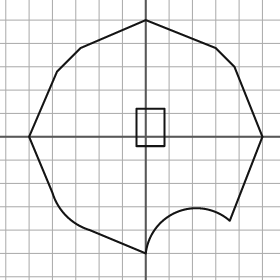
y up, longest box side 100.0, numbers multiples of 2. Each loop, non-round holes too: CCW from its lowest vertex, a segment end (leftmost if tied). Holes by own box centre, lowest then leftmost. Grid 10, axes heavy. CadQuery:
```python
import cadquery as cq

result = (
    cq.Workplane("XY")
    .moveTo(0.0, -50.0)
    .threePointArc((14.0, -32.0), (36.0, -36.0))
    .lineTo(50.0, 0.0)
    .lineTo(38.0, 30.0)
    .lineTo(30.0, 38.0)
    .lineTo(0.0, 50.0)
    .lineTo(-28.0, 38.0)
    .lineTo(-38.0, 28.0)
    .lineTo(-50.0, 0.0)
    .lineTo(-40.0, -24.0)
    .threePointArc((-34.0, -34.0), (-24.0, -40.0))
    .close()
    .moveTo(-4.0, -4.0)
    .lineTo(8.0, -4.0)
    .lineTo(8.0, 12.0)
    .lineTo(-4.0, 12.0)
    .close()
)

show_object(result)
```